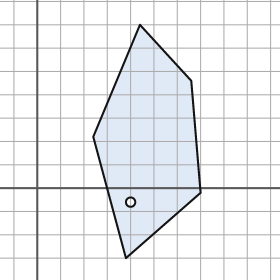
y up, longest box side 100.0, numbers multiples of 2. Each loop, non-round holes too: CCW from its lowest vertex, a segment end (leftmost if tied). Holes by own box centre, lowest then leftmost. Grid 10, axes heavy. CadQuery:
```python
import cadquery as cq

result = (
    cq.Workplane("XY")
    .moveTo(38.0, -30.0)
    .lineTo(70.0, -2.0)
    .lineTo(66.0, 46.0)
    .lineTo(44.0, 70.0)
    .lineTo(24.0, 22.0)
    .close()
    .moveTo(40.0, -6.0)
    .circle(2.0)
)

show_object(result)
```